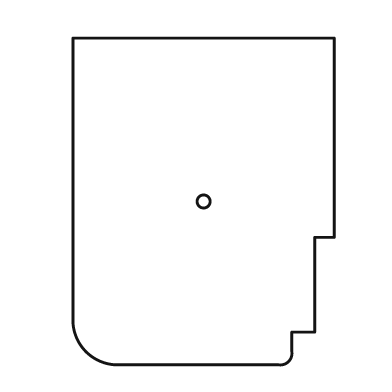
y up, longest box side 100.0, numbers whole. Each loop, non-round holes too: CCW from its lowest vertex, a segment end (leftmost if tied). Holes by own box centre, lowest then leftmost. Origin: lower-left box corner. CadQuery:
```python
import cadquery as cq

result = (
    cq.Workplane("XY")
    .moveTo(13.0, 0.0)
    .lineTo(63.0, 0.0)
    .threePointArc((66.0, 1.0), (67.0, 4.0))
    .lineTo(67.0, 10.0)
    .lineTo(74.0, 10.0)
    .lineTo(74.0, 39.0)
    .lineTo(80.0, 39.0)
    .lineTo(80.0, 100.0)
    .lineTo(0.0, 100.0)
    .lineTo(0.0, 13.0)
    .threePointArc((4.0, 4.0), (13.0, 0.0))
    .close()
    .moveTo(40.0, 50.0)
    .circle(2.0)
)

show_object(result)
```